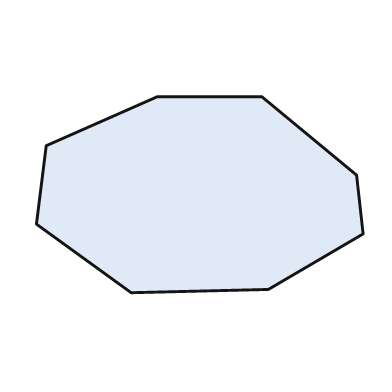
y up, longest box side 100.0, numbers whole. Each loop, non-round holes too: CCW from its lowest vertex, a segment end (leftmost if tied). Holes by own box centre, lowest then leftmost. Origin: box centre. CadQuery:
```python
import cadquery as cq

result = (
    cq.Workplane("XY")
    .moveTo(-21.0, -30.0)
    .lineTo(21.0, -29.0)
    .lineTo(50.0, -12.0)
    .lineTo(48.0, 6.0)
    .lineTo(19.0, 30.0)
    .lineTo(-13.0, 30.0)
    .lineTo(-47.0, 15.0)
    .lineTo(-50.0, -9.0)
    .close()
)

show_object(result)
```